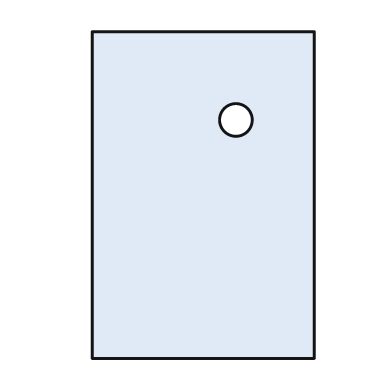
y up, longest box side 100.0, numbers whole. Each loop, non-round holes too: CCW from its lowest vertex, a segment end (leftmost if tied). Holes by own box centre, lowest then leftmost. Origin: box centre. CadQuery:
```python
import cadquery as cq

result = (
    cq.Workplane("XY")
    .moveTo(-34.0, -50.0)
    .lineTo(34.0, -50.0)
    .lineTo(34.0, 50.0)
    .lineTo(-34.0, 50.0)
    .close()
    .moveTo(10.0, 23.0)
    .circle(5.0)
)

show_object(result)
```